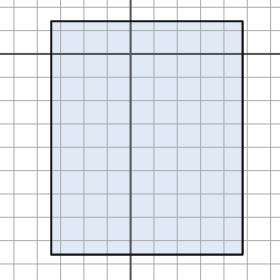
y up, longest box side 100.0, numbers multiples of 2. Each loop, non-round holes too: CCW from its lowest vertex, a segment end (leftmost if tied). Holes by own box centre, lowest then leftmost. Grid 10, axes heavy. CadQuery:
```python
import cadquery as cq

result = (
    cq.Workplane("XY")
    .moveTo(-34.0, -86.0)
    .lineTo(48.0, -86.0)
    .lineTo(48.0, 14.0)
    .lineTo(-34.0, 14.0)
    .close()
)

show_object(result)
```